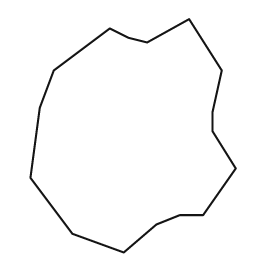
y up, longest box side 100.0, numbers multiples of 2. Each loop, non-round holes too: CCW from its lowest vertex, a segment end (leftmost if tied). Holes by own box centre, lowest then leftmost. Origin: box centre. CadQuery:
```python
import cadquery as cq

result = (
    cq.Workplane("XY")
    .moveTo(-4.0, -50.0)
    .lineTo(10.0, -38.0)
    .lineTo(20.0, -34.0)
    .lineTo(30.0, -34.0)
    .lineTo(44.0, -14.0)
    .lineTo(34.0, 2.0)
    .lineTo(34.0, 10.0)
    .lineTo(38.0, 28.0)
    .lineTo(24.0, 50.0)
    .lineTo(6.0, 40.0)
    .lineTo(-2.0, 42.0)
    .lineTo(-10.0, 46.0)
    .lineTo(-34.0, 28.0)
    .lineTo(-40.0, 12.0)
    .lineTo(-44.0, -18.0)
    .lineTo(-26.0, -42.0)
    .close()
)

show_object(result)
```